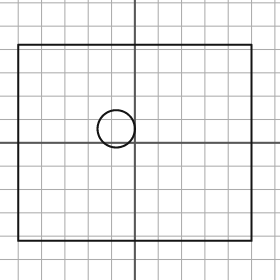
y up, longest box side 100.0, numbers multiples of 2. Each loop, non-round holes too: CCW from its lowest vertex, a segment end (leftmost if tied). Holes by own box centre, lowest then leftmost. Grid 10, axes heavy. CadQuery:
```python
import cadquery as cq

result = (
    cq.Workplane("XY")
    .moveTo(-50.0, -42.0)
    .lineTo(50.0, -42.0)
    .lineTo(50.0, 42.0)
    .lineTo(-50.0, 42.0)
    .close()
    .moveTo(-8.0, 6.0)
    .circle(8.0)
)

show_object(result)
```